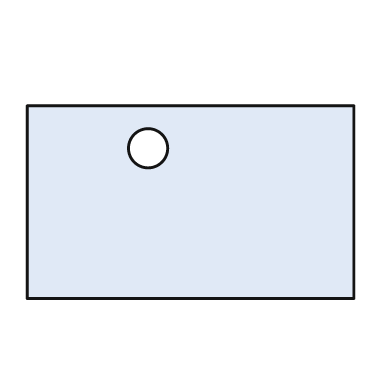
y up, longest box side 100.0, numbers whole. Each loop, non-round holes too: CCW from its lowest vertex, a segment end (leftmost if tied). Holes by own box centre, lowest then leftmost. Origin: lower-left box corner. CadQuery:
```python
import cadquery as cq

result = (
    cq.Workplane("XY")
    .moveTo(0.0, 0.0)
    .lineTo(100.0, 0.0)
    .lineTo(100.0, 59.0)
    .lineTo(0.0, 59.0)
    .close()
    .moveTo(37.0, 46.0)
    .circle(6.0)
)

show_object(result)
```